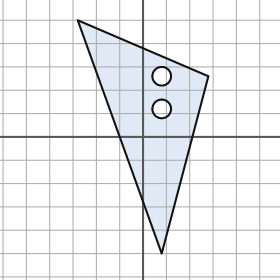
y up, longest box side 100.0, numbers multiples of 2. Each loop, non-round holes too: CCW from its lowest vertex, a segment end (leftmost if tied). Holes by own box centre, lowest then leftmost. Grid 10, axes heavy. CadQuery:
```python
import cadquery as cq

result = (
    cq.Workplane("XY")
    .moveTo(8.0, -50.0)
    .lineTo(28.0, 26.0)
    .lineTo(-28.0, 50.0)
    .close()
    .moveTo(8.0, 12.0)
    .circle(4.0)
    .moveTo(8.0, 26.0)
    .circle(4.0)
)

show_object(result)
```